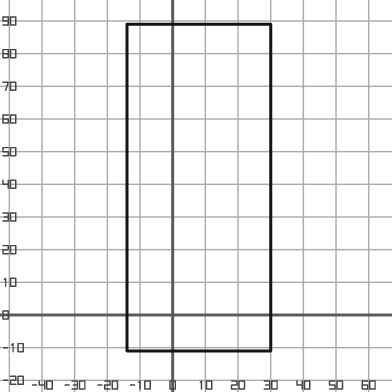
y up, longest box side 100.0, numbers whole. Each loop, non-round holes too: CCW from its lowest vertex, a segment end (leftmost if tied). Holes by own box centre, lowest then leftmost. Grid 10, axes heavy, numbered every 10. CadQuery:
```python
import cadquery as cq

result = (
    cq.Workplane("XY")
    .moveTo(-14.0, -11.0)
    .lineTo(30.0, -11.0)
    .lineTo(30.0, 89.0)
    .lineTo(-14.0, 89.0)
    .close()
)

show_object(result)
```